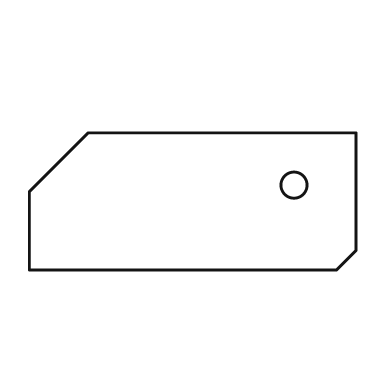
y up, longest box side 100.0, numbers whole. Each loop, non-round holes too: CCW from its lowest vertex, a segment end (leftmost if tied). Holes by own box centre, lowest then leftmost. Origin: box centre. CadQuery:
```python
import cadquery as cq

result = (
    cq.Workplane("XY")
    .moveTo(-50.0, -21.0)
    .lineTo(44.0, -21.0)
    .lineTo(50.0, -15.0)
    .lineTo(50.0, 21.0)
    .lineTo(-32.0, 21.0)
    .lineTo(-50.0, 3.0)
    .close()
    .moveTo(31.0, 5.0)
    .circle(4.0)
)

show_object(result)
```